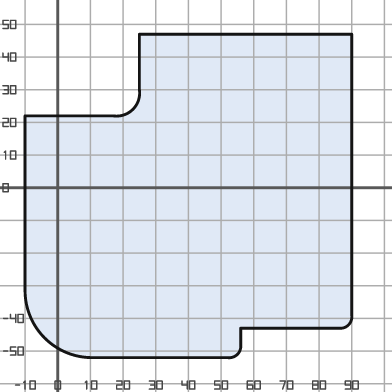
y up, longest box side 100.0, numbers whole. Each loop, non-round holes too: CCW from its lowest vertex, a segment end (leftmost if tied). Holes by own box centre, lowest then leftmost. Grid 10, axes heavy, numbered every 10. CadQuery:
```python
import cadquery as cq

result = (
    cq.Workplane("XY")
    .moveTo(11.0, -52.0)
    .lineTo(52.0, -52.0)
    .threePointArc((55.0, -51.0), (56.0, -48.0))
    .lineTo(56.0, -43.0)
    .lineTo(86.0, -43.0)
    .threePointArc((89.0, -42.0), (90.0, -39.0))
    .lineTo(90.0, 47.0)
    .lineTo(25.0, 47.0)
    .lineTo(25.0, 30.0)
    .threePointArc((23.0, 24.0), (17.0, 22.0))
    .lineTo(-10.0, 22.0)
    .lineTo(-10.0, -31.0)
    .threePointArc((-4.0, -46.0), (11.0, -52.0))
    .close()
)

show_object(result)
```